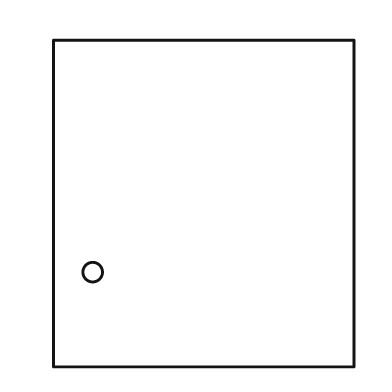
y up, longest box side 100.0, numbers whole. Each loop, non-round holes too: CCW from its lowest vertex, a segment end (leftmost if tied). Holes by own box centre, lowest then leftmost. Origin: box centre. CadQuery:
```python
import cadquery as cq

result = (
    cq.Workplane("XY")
    .moveTo(-46.0, -50.0)
    .lineTo(46.0, -50.0)
    .lineTo(46.0, 50.0)
    .lineTo(-46.0, 50.0)
    .close()
    .moveTo(-34.0, -21.0)
    .circle(3.0)
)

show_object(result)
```